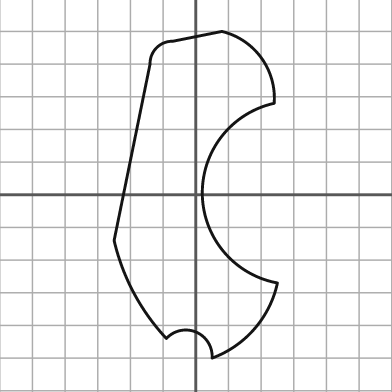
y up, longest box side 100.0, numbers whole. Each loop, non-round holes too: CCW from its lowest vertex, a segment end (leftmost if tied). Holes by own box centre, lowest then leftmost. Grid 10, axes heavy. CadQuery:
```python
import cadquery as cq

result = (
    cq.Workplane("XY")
    .moveTo(5.0, -50.0)
    .threePointArc((18.0, -41.0), (25.0, -27.0))
    .threePointArc((2.0, 0.0), (24.0, 28.0))
    .threePointArc((20.0, 42.0), (8.0, 50.0))
    .lineTo(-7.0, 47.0)
    .threePointArc((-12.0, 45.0), (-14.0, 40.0))
    .lineTo(-25.0, -14.0)
    .threePointArc((-19.0, -30.0), (-9.0, -44.0))
    .threePointArc((0.0, -42.0), (5.0, -50.0))
    .close()
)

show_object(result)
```